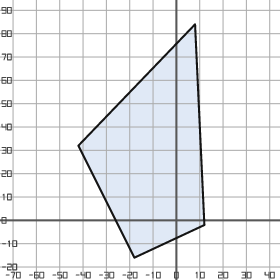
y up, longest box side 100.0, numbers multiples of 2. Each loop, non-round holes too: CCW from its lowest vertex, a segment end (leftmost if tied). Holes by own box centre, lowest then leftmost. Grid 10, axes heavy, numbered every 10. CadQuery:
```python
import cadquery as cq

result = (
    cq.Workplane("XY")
    .moveTo(-18.0, -16.0)
    .lineTo(12.0, -2.0)
    .lineTo(8.0, 84.0)
    .lineTo(-42.0, 32.0)
    .close()
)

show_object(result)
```